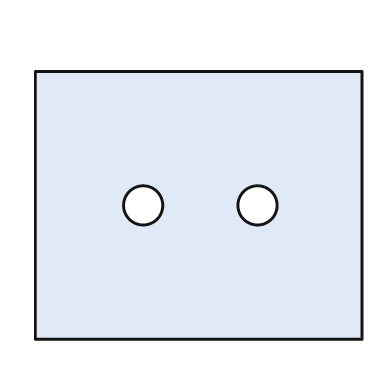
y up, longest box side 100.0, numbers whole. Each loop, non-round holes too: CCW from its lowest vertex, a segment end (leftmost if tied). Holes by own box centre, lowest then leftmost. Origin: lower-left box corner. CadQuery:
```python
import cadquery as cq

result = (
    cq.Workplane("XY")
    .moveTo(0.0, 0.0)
    .lineTo(100.0, 0.0)
    .lineTo(100.0, 82.0)
    .lineTo(0.0, 82.0)
    .close()
    .moveTo(33.0, 41.0)
    .circle(6.0)
    .moveTo(68.0, 41.0)
    .circle(6.0)
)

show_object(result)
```